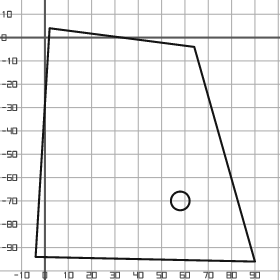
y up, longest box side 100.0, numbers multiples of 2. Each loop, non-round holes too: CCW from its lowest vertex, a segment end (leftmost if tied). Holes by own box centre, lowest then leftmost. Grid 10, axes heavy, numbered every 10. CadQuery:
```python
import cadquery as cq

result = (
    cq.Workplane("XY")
    .moveTo(90.0, -96.0)
    .lineTo(64.0, -4.0)
    .lineTo(2.0, 4.0)
    .lineTo(-4.0, -94.0)
    .close()
    .moveTo(58.0, -70.0)
    .circle(4.0)
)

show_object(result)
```